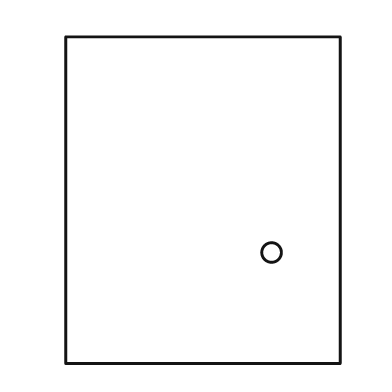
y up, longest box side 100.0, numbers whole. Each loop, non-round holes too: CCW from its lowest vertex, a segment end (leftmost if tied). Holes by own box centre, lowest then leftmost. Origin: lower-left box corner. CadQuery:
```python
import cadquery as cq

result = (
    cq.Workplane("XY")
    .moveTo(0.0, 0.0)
    .lineTo(84.0, 0.0)
    .lineTo(84.0, 100.0)
    .lineTo(0.0, 100.0)
    .close()
    .moveTo(63.0, 34.0)
    .circle(3.0)
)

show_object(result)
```